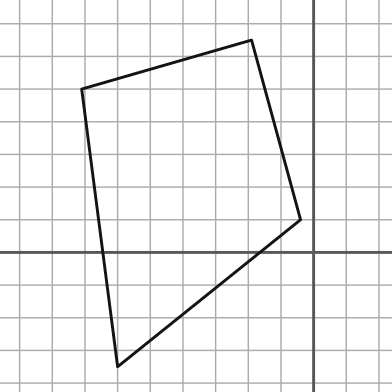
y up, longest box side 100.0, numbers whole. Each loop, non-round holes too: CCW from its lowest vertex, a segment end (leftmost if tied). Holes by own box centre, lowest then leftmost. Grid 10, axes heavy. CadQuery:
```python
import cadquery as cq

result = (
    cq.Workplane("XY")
    .moveTo(-60.0, -35.0)
    .lineTo(-4.0, 10.0)
    .lineTo(-19.0, 65.0)
    .lineTo(-71.0, 50.0)
    .close()
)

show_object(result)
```